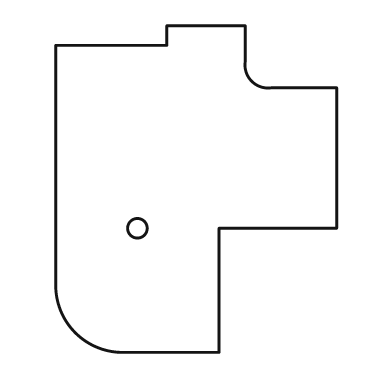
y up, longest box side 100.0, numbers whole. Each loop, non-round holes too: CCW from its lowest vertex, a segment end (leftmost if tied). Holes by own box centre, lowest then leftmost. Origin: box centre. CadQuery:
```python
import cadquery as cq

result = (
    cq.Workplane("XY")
    .moveTo(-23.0, -50.0)
    .lineTo(7.0, -50.0)
    .lineTo(7.0, -12.0)
    .lineTo(43.0, -12.0)
    .lineTo(43.0, 31.0)
    .lineTo(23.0, 31.0)
    .threePointArc((17.0, 33.0), (15.0, 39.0))
    .lineTo(15.0, 50.0)
    .lineTo(-9.0, 50.0)
    .lineTo(-9.0, 44.0)
    .lineTo(-43.0, 44.0)
    .lineTo(-43.0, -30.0)
    .threePointArc((-37.0, -44.0), (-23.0, -50.0))
    .close()
    .moveTo(-18.0, -12.0)
    .circle(3.0)
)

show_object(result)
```